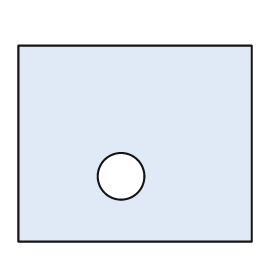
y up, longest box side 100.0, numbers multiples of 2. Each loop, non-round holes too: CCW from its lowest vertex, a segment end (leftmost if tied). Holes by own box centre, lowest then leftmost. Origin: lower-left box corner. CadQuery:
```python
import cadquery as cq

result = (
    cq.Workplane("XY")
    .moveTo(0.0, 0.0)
    .lineTo(100.0, 0.0)
    .lineTo(100.0, 84.0)
    .lineTo(0.0, 84.0)
    .close()
    .moveTo(44.0, 28.0)
    .circle(10.0)
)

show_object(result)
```